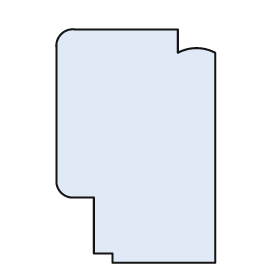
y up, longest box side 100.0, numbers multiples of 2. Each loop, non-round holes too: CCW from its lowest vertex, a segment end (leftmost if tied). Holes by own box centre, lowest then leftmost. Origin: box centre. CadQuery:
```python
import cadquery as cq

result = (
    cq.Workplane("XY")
    .moveTo(-10.0, -50.0)
    .lineTo(34.0, -50.0)
    .lineTo(34.0, 40.0)
    .threePointArc((26.0, 42.0), (18.0, 40.0))
    .lineTo(18.0, 50.0)
    .lineTo(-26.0, 50.0)
    .threePointArc((-32.0, 48.0), (-34.0, 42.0))
    .lineTo(-34.0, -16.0)
    .threePointArc((-32.0, -20.0), (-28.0, -22.0))
    .lineTo(-18.0, -22.0)
    .lineTo(-18.0, -46.0)
    .lineTo(-10.0, -46.0)
    .close()
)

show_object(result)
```